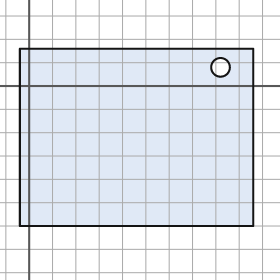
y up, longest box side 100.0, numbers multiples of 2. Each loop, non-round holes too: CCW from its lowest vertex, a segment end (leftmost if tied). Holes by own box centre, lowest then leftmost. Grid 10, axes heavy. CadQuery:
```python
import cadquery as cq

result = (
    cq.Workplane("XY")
    .moveTo(-4.0, -60.0)
    .lineTo(96.0, -60.0)
    .lineTo(96.0, 16.0)
    .lineTo(-4.0, 16.0)
    .close()
    .moveTo(82.0, 8.0)
    .circle(4.0)
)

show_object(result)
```